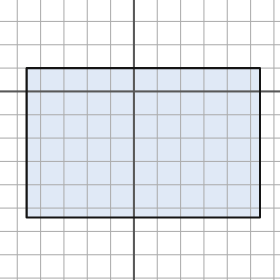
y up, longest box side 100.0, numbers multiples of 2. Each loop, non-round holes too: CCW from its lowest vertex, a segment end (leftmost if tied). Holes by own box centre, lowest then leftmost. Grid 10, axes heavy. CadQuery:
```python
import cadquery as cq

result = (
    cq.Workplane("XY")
    .moveTo(-46.0, -54.0)
    .lineTo(54.0, -54.0)
    .lineTo(54.0, 10.0)
    .lineTo(-46.0, 10.0)
    .close()
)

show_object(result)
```